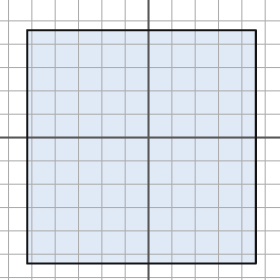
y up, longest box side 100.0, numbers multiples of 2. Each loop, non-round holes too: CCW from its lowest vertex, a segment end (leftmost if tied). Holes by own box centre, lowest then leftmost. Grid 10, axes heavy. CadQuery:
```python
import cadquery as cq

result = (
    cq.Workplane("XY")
    .moveTo(-52.0, -54.0)
    .lineTo(46.0, -54.0)
    .lineTo(46.0, 46.0)
    .lineTo(-52.0, 46.0)
    .close()
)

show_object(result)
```